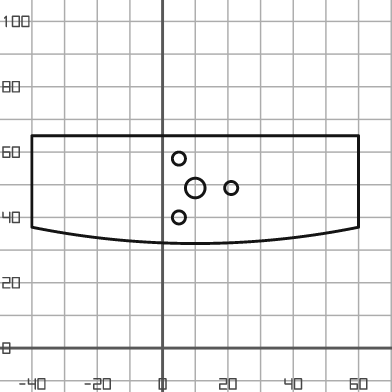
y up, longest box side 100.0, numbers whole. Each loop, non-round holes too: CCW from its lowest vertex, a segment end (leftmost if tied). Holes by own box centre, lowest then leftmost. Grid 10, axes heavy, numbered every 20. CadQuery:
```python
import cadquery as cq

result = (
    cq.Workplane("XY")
    .moveTo(-40.0, 37.0)
    .threePointArc((10.0, 32.0), (60.0, 37.0))
    .lineTo(60.0, 65.0)
    .lineTo(-40.0, 65.0)
    .close()
    .moveTo(5.0, 40.0)
    .circle(2.0)
    .moveTo(10.0, 49.0)
    .circle(3.0)
    .moveTo(21.0, 49.0)
    .circle(2.0)
    .moveTo(5.0, 58.0)
    .circle(2.0)
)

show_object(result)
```